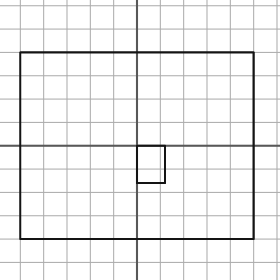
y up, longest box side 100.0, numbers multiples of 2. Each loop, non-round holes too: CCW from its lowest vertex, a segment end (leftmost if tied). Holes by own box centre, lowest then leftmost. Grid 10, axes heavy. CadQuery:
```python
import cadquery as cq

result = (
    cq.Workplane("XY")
    .moveTo(-50.0, -40.0)
    .lineTo(50.0, -40.0)
    .lineTo(50.0, 40.0)
    .lineTo(-50.0, 40.0)
    .close()
    .moveTo(0.0, -16.0)
    .lineTo(12.0, -16.0)
    .lineTo(12.0, 0.0)
    .lineTo(0.0, 0.0)
    .close()
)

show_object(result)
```